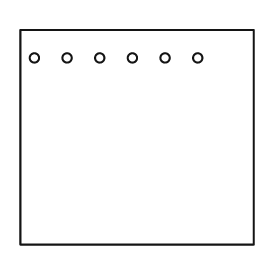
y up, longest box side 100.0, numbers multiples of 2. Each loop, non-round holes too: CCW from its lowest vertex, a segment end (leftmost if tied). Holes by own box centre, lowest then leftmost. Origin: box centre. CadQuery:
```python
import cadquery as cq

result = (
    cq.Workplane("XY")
    .moveTo(-50.0, -46.0)
    .lineTo(50.0, -46.0)
    .lineTo(50.0, 46.0)
    .lineTo(-50.0, 46.0)
    .close()
    .moveTo(-44.0, 34.0)
    .circle(2.0)
    .moveTo(-30.0, 34.0)
    .circle(2.0)
    .moveTo(-16.0, 34.0)
    .circle(2.0)
    .moveTo(-2.0, 34.0)
    .circle(2.0)
    .moveTo(12.0, 34.0)
    .circle(2.0)
    .moveTo(26.0, 34.0)
    .circle(2.0)
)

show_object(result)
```